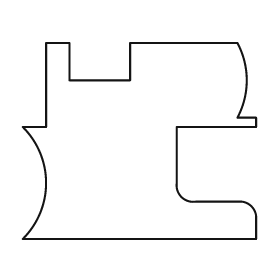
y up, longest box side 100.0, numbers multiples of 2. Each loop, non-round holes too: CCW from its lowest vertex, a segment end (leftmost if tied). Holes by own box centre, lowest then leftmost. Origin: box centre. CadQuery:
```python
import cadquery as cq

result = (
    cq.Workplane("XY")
    .moveTo(-50.0, -42.0)
    .lineTo(50.0, -42.0)
    .lineTo(50.0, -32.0)
    .threePointArc((48.0, -28.0), (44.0, -26.0))
    .lineTo(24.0, -26.0)
    .threePointArc((18.0, -24.0), (16.0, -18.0))
    .lineTo(16.0, 6.0)
    .lineTo(50.0, 6.0)
    .lineTo(50.0, 10.0)
    .lineTo(42.0, 10.0)
    .threePointArc((46.0, 26.0), (42.0, 42.0))
    .lineTo(-4.0, 42.0)
    .lineTo(-4.0, 26.0)
    .lineTo(-30.0, 26.0)
    .lineTo(-30.0, 42.0)
    .lineTo(-40.0, 42.0)
    .lineTo(-40.0, 6.0)
    .lineTo(-50.0, 6.0)
    .threePointArc((-40.0, -18.0), (-50.0, -42.0))
    .close()
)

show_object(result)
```